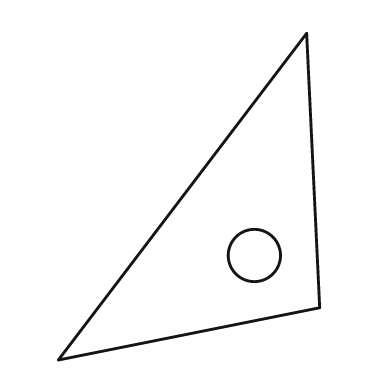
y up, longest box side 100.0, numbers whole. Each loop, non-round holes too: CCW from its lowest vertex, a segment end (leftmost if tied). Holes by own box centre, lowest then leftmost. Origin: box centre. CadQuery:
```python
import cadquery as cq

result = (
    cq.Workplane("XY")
    .moveTo(-40.0, -50.0)
    .lineTo(40.0, -34.0)
    .lineTo(36.0, 50.0)
    .close()
    .moveTo(20.0, -18.0)
    .circle(8.0)
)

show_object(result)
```